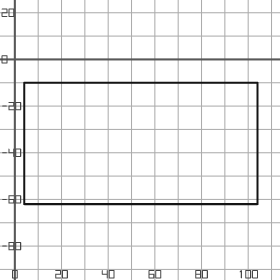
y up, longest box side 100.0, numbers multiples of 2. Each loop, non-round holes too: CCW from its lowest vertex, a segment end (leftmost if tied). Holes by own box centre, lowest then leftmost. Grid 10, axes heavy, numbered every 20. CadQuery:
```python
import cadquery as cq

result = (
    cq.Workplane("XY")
    .moveTo(4.0, -62.0)
    .lineTo(104.0, -62.0)
    .lineTo(104.0, -10.0)
    .lineTo(4.0, -10.0)
    .close()
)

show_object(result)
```